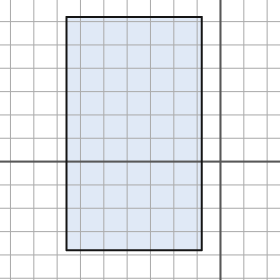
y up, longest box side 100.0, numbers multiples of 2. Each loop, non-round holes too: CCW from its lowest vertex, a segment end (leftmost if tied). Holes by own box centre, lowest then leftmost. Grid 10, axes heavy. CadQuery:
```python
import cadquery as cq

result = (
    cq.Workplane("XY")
    .moveTo(-66.0, -38.0)
    .lineTo(-8.0, -38.0)
    .lineTo(-8.0, 62.0)
    .lineTo(-66.0, 62.0)
    .close()
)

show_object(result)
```